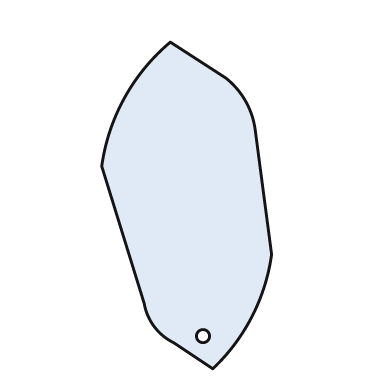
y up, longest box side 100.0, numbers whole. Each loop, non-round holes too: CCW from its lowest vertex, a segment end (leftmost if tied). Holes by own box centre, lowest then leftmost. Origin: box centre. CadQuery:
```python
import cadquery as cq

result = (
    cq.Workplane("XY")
    .moveTo(8.0, -50.0)
    .threePointArc((20.0, -34.0), (26.0, -15.0))
    .lineTo(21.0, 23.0)
    .threePointArc((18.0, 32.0), (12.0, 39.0))
    .lineTo(-5.0, 50.0)
    .threePointArc((-19.0, 33.0), (-26.0, 12.0))
    .lineTo(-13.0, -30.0)
    .threePointArc((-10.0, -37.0), (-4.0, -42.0))
    .close()
    .moveTo(5.0, -40.0)
    .circle(2.0)
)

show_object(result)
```